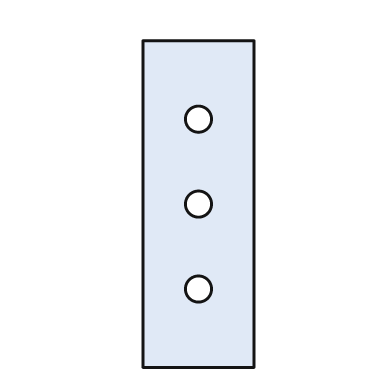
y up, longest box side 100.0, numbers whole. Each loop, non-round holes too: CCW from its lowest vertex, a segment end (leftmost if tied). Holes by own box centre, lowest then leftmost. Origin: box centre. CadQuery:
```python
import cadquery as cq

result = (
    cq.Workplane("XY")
    .moveTo(-17.0, -50.0)
    .lineTo(17.0, -50.0)
    .lineTo(17.0, 50.0)
    .lineTo(-17.0, 50.0)
    .close()
    .moveTo(0.0, -26.0)
    .circle(4.0)
    .moveTo(0.0, 0.0)
    .circle(4.0)
    .moveTo(0.0, 26.0)
    .circle(4.0)
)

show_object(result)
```